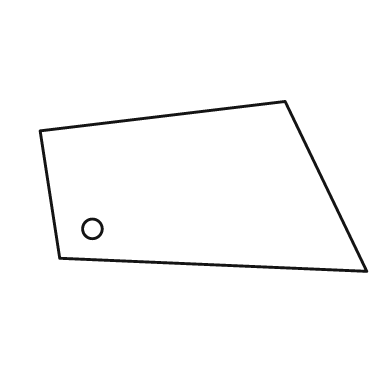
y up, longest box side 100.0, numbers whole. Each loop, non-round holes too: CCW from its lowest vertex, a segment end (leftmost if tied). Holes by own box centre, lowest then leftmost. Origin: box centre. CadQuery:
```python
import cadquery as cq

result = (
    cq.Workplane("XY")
    .moveTo(50.0, -26.0)
    .lineTo(25.0, 26.0)
    .lineTo(-50.0, 17.0)
    .lineTo(-44.0, -22.0)
    .close()
    .moveTo(-34.0, -13.0)
    .circle(3.0)
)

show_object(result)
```